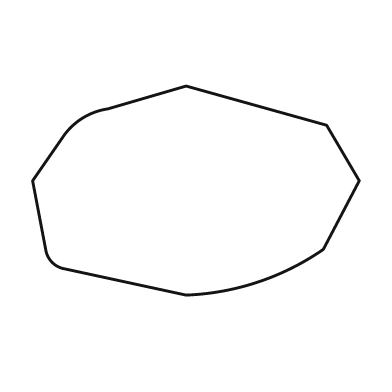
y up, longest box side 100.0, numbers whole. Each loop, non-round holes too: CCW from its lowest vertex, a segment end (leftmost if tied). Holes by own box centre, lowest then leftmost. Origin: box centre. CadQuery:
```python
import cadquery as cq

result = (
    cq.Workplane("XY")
    .moveTo(-3.0, -32.0)
    .threePointArc((19.0, -28.0), (39.0, -18.0))
    .lineTo(50.0, 3.0)
    .lineTo(40.0, 20.0)
    .lineTo(-3.0, 32.0)
    .lineTo(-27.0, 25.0)
    .threePointArc((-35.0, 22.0), (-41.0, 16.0))
    .lineTo(-50.0, 3.0)
    .lineTo(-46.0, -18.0)
    .threePointArc((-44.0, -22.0), (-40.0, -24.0))
    .close()
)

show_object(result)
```